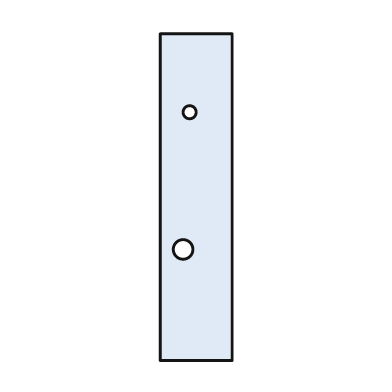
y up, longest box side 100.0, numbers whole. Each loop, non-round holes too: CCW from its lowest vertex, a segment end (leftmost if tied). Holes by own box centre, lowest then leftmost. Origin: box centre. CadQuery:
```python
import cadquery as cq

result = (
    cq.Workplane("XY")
    .moveTo(-11.0, -50.0)
    .lineTo(11.0, -50.0)
    .lineTo(11.0, 50.0)
    .lineTo(-11.0, 50.0)
    .close()
    .moveTo(-4.0, -16.0)
    .circle(3.0)
    .moveTo(-2.0, 26.0)
    .circle(2.0)
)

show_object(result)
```